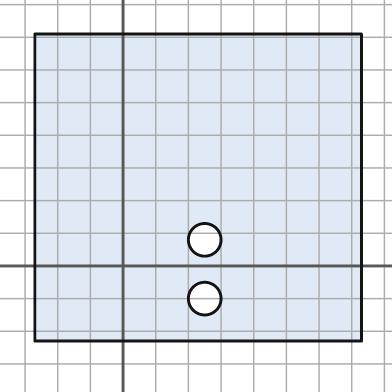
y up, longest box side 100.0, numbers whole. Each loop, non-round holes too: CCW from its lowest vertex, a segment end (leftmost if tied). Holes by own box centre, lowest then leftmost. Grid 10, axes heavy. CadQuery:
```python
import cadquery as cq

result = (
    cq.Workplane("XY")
    .moveTo(-27.0, -23.0)
    .lineTo(73.0, -23.0)
    .lineTo(73.0, 71.0)
    .lineTo(-27.0, 71.0)
    .close()
    .moveTo(25.0, -10.0)
    .circle(5.0)
    .moveTo(25.0, 8.0)
    .circle(5.0)
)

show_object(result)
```